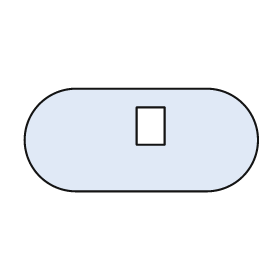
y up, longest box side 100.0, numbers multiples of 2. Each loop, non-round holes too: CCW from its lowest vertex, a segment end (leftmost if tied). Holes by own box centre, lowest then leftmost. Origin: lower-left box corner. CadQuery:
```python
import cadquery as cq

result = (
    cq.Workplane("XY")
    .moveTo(22.0, 0.0)
    .lineTo(78.0, 0.0)
    .threePointArc((100.0, 22.0), (78.0, 44.0))
    .lineTo(22.0, 44.0)
    .threePointArc((0.0, 22.0), (22.0, 0.0))
    .close()
    .moveTo(48.0, 20.0)
    .lineTo(60.0, 20.0)
    .lineTo(60.0, 36.0)
    .lineTo(48.0, 36.0)
    .close()
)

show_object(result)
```